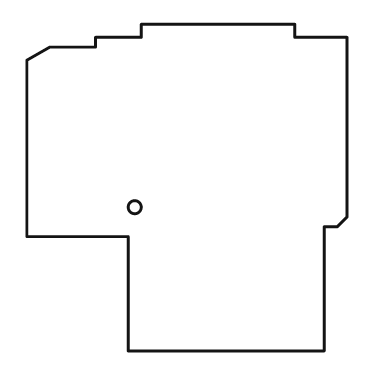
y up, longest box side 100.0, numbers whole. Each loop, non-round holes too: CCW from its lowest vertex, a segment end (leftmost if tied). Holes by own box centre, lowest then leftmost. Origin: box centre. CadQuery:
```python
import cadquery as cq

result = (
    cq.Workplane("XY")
    .moveTo(-18.0, -50.0)
    .lineTo(42.0, -50.0)
    .lineTo(42.0, -12.0)
    .lineTo(46.0, -12.0)
    .lineTo(49.0, -9.0)
    .lineTo(49.0, 46.0)
    .lineTo(33.0, 46.0)
    .lineTo(33.0, 50.0)
    .lineTo(-14.0, 50.0)
    .lineTo(-14.0, 46.0)
    .lineTo(-28.0, 46.0)
    .lineTo(-28.0, 43.0)
    .lineTo(-42.0, 43.0)
    .lineTo(-49.0, 39.0)
    .lineTo(-49.0, -15.0)
    .lineTo(-18.0, -15.0)
    .close()
    .moveTo(-16.0, -6.0)
    .circle(2.0)
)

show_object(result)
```